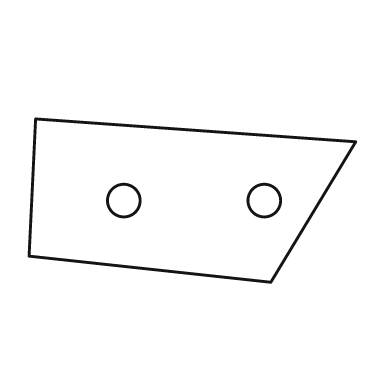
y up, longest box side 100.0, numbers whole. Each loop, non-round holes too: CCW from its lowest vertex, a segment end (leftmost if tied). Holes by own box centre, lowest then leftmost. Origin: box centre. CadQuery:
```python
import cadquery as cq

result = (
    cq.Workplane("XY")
    .moveTo(24.0, -25.0)
    .lineTo(50.0, 18.0)
    .lineTo(-48.0, 25.0)
    .lineTo(-50.0, -17.0)
    .close()
    .moveTo(-21.0, 0.0)
    .circle(5.0)
    .moveTo(22.0, 0.0)
    .circle(5.0)
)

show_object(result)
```